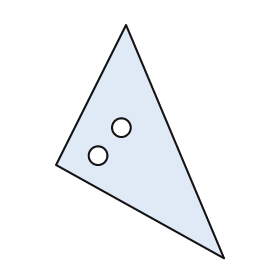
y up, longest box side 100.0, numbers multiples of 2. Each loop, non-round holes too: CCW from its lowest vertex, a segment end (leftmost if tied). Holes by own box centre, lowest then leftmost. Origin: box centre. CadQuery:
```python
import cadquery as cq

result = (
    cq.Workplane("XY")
    .moveTo(36.0, -50.0)
    .lineTo(-6.0, 50.0)
    .lineTo(-36.0, -10.0)
    .close()
    .moveTo(-18.0, -6.0)
    .circle(4.0)
    .moveTo(-8.0, 6.0)
    .circle(4.0)
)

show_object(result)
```